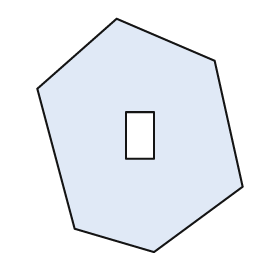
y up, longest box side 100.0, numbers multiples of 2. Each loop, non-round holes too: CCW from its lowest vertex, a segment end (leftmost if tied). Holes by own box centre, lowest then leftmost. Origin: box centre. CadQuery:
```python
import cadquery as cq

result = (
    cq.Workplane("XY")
    .moveTo(6.0, -50.0)
    .lineTo(44.0, -22.0)
    .lineTo(32.0, 32.0)
    .lineTo(-10.0, 50.0)
    .lineTo(-44.0, 20.0)
    .lineTo(-28.0, -40.0)
    .close()
    .moveTo(-6.0, -10.0)
    .lineTo(6.0, -10.0)
    .lineTo(6.0, 10.0)
    .lineTo(-6.0, 10.0)
    .close()
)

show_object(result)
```